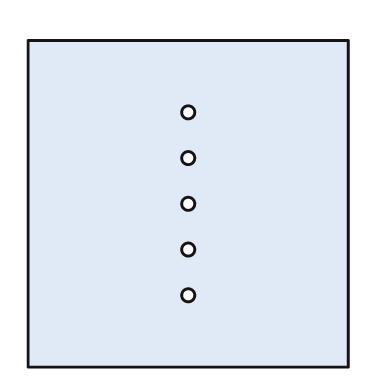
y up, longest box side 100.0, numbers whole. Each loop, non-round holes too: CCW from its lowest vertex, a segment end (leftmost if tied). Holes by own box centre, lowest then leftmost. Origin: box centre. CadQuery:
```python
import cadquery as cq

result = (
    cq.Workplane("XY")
    .moveTo(-49.0, -50.0)
    .lineTo(49.0, -50.0)
    .lineTo(49.0, 50.0)
    .lineTo(-49.0, 50.0)
    .close()
    .moveTo(0.0, -28.0)
    .circle(2.0)
    .moveTo(0.0, -14.0)
    .circle(2.0)
    .moveTo(0.0, 0.0)
    .circle(2.0)
    .moveTo(0.0, 14.0)
    .circle(2.0)
    .moveTo(0.0, 28.0)
    .circle(2.0)
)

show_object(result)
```